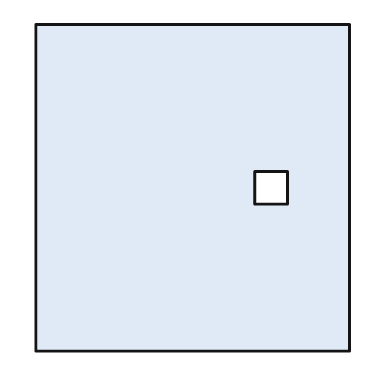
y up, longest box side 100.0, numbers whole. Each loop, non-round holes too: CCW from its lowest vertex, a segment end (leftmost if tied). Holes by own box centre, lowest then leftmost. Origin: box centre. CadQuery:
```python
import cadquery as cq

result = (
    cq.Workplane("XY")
    .moveTo(-48.0, -50.0)
    .lineTo(48.0, -50.0)
    .lineTo(48.0, 50.0)
    .lineTo(-48.0, 50.0)
    .close()
    .moveTo(19.0, -5.0)
    .lineTo(29.0, -5.0)
    .lineTo(29.0, 5.0)
    .lineTo(19.0, 5.0)
    .close()
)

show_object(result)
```